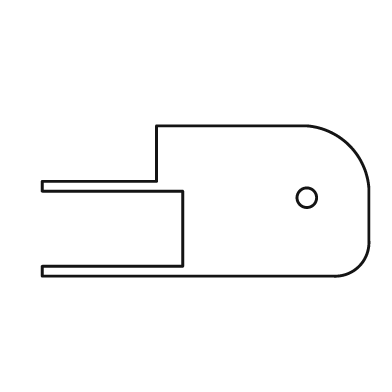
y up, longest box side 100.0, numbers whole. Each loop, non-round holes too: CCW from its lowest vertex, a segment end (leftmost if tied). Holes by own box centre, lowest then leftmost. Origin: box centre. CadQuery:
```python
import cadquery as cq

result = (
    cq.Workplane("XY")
    .moveTo(-50.0, -23.0)
    .lineTo(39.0, -23.0)
    .threePointArc((47.0, -20.0), (50.0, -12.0))
    .lineTo(50.0, 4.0)
    .threePointArc((44.0, 17.0), (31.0, 23.0))
    .lineTo(-15.0, 23.0)
    .lineTo(-15.0, 6.0)
    .lineTo(-50.0, 6.0)
    .lineTo(-50.0, 3.0)
    .lineTo(-7.0, 3.0)
    .lineTo(-7.0, -20.0)
    .lineTo(-50.0, -20.0)
    .close()
    .moveTo(31.0, 1.0)
    .circle(3.0)
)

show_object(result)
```